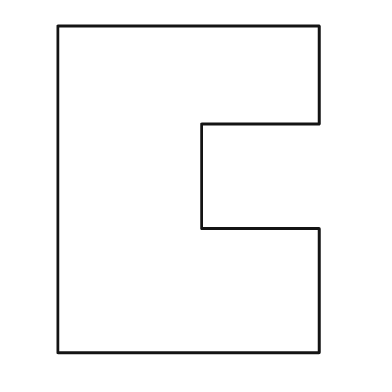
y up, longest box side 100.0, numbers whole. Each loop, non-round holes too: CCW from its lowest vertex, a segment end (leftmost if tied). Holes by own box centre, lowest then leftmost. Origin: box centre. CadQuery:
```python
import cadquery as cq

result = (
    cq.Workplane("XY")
    .moveTo(-40.0, -50.0)
    .lineTo(40.0, -50.0)
    .lineTo(40.0, -12.0)
    .lineTo(4.0, -12.0)
    .lineTo(4.0, 20.0)
    .lineTo(40.0, 20.0)
    .lineTo(40.0, 50.0)
    .lineTo(-40.0, 50.0)
    .close()
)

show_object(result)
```